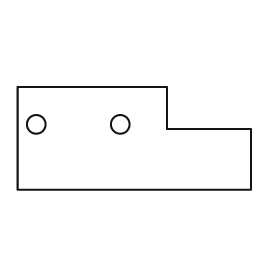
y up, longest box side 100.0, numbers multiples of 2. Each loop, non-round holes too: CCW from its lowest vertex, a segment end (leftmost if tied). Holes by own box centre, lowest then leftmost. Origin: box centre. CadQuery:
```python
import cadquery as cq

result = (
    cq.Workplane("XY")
    .moveTo(-50.0, -22.0)
    .lineTo(50.0, -22.0)
    .lineTo(50.0, 4.0)
    .lineTo(14.0, 4.0)
    .lineTo(14.0, 22.0)
    .lineTo(-50.0, 22.0)
    .close()
    .moveTo(-42.0, 6.0)
    .circle(4.0)
    .moveTo(-6.0, 6.0)
    .circle(4.0)
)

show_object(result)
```